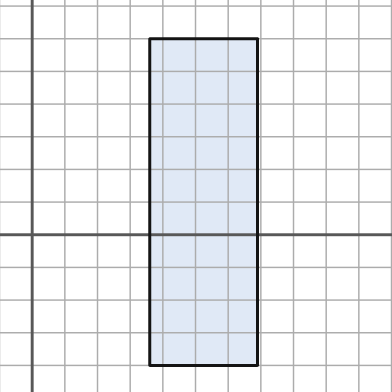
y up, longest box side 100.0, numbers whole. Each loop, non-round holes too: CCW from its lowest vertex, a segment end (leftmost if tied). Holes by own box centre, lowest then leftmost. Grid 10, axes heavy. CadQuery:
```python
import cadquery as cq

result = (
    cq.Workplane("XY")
    .moveTo(36.0, -40.0)
    .lineTo(69.0, -40.0)
    .lineTo(69.0, 60.0)
    .lineTo(36.0, 60.0)
    .close()
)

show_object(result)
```